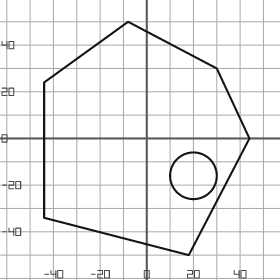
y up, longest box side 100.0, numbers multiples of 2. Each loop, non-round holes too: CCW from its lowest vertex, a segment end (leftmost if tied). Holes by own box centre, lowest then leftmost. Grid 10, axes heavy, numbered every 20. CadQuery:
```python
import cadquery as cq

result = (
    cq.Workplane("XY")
    .moveTo(18.0, -50.0)
    .lineTo(44.0, 0.0)
    .lineTo(30.0, 30.0)
    .lineTo(-8.0, 50.0)
    .lineTo(-44.0, 24.0)
    .lineTo(-44.0, -34.0)
    .close()
    .moveTo(20.0, -16.0)
    .circle(10.0)
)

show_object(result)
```